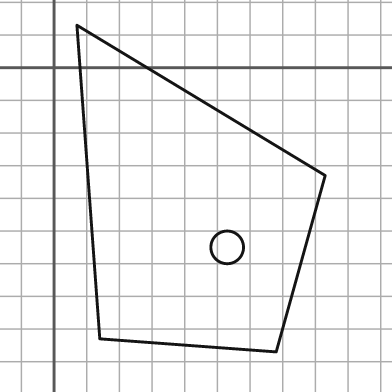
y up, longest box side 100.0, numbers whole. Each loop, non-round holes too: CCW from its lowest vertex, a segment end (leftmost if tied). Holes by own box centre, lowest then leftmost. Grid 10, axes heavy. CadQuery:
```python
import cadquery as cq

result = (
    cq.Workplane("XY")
    .moveTo(68.0, -87.0)
    .lineTo(83.0, -33.0)
    .lineTo(7.0, 13.0)
    .lineTo(14.0, -83.0)
    .close()
    .moveTo(53.0, -55.0)
    .circle(5.0)
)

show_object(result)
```